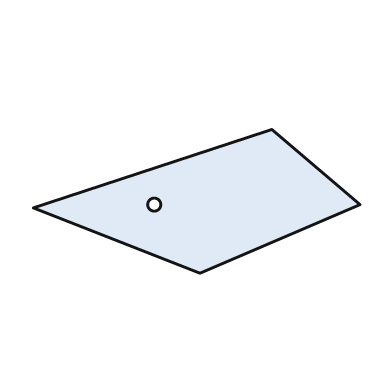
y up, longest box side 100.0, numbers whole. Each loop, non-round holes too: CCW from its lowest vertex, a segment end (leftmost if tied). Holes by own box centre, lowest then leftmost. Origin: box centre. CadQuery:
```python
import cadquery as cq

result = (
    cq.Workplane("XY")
    .moveTo(1.0, -22.0)
    .lineTo(50.0, -1.0)
    .lineTo(23.0, 22.0)
    .lineTo(-50.0, -2.0)
    .close()
    .moveTo(-13.0, -1.0)
    .circle(2.0)
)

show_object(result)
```